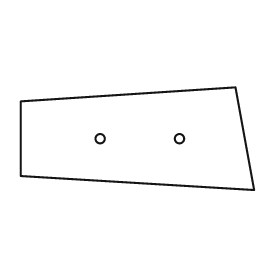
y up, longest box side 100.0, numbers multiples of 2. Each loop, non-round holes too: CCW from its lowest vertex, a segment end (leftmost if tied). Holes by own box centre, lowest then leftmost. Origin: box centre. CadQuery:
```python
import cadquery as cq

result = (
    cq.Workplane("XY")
    .moveTo(50.0, -22.0)
    .lineTo(42.0, 22.0)
    .lineTo(-50.0, 16.0)
    .lineTo(-50.0, -16.0)
    .close()
    .moveTo(-16.0, 0.0)
    .circle(2.0)
    .moveTo(18.0, 0.0)
    .circle(2.0)
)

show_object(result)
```